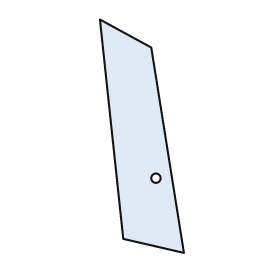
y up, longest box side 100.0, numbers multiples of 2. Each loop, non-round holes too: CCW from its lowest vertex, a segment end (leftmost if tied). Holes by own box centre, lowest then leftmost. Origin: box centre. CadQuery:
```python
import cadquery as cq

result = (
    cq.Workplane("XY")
    .moveTo(18.0, -50.0)
    .lineTo(4.0, 38.0)
    .lineTo(-18.0, 50.0)
    .lineTo(-8.0, -44.0)
    .close()
    .moveTo(6.0, -18.0)
    .circle(2.0)
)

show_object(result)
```